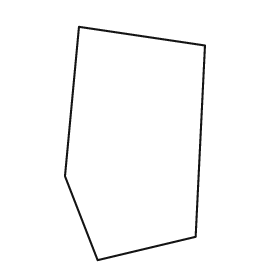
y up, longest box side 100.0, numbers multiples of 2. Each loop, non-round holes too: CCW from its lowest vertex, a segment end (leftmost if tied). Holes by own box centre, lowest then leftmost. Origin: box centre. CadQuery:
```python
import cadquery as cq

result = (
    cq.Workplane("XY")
    .moveTo(-16.0, -50.0)
    .lineTo(26.0, -40.0)
    .lineTo(30.0, 42.0)
    .lineTo(-24.0, 50.0)
    .lineTo(-30.0, -14.0)
    .close()
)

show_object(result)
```